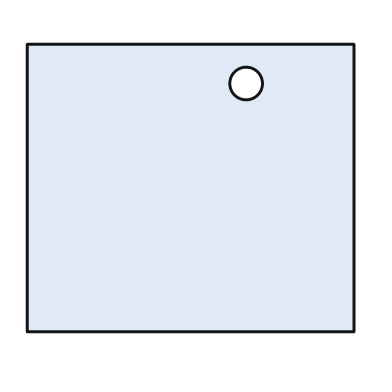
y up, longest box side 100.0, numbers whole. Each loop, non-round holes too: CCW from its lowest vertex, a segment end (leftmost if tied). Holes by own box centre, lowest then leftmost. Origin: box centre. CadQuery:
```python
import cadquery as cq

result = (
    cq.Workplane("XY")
    .moveTo(-50.0, -44.0)
    .lineTo(50.0, -44.0)
    .lineTo(50.0, 44.0)
    .lineTo(-50.0, 44.0)
    .close()
    .moveTo(17.0, 32.0)
    .circle(5.0)
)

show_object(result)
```